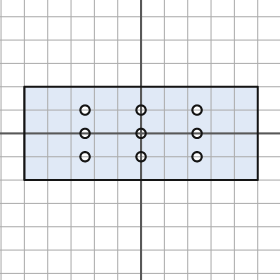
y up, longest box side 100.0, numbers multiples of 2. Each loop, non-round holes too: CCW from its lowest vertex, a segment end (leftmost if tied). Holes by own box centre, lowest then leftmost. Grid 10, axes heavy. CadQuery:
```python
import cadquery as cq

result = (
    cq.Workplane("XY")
    .moveTo(-50.0, -20.0)
    .lineTo(50.0, -20.0)
    .lineTo(50.0, 20.0)
    .lineTo(-50.0, 20.0)
    .close()
    .moveTo(-24.0, -10.0)
    .circle(2.0)
    .moveTo(0.0, -10.0)
    .circle(2.0)
    .moveTo(24.0, -10.0)
    .circle(2.0)
    .moveTo(-24.0, 0.0)
    .circle(2.0)
    .moveTo(0.0, 0.0)
    .circle(2.0)
    .moveTo(24.0, 0.0)
    .circle(2.0)
    .moveTo(-24.0, 10.0)
    .circle(2.0)
    .moveTo(0.0, 10.0)
    .circle(2.0)
    .moveTo(24.0, 10.0)
    .circle(2.0)
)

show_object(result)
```